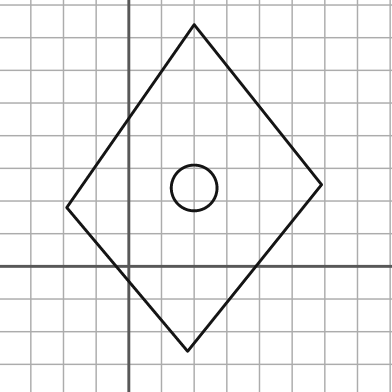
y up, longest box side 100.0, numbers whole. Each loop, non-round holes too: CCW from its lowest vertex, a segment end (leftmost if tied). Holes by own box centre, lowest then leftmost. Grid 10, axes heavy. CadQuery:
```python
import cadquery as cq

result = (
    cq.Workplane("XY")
    .moveTo(18.0, -26.0)
    .lineTo(59.0, 25.0)
    .lineTo(20.0, 74.0)
    .lineTo(-19.0, 18.0)
    .close()
    .moveTo(20.0, 24.0)
    .circle(7.0)
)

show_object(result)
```